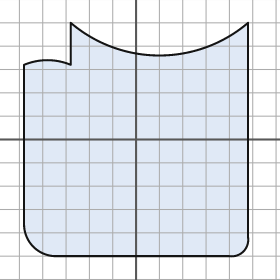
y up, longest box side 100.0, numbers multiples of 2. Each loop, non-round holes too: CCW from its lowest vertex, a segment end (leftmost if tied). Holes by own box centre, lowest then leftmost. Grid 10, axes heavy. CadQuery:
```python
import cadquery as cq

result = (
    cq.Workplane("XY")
    .moveTo(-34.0, -50.0)
    .lineTo(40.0, -50.0)
    .threePointArc((46.0, -48.0), (48.0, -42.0))
    .lineTo(48.0, 50.0)
    .threePointArc((10.0, 36.0), (-28.0, 50.0))
    .lineTo(-28.0, 32.0)
    .threePointArc((-38.0, 34.0), (-48.0, 32.0))
    .lineTo(-48.0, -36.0)
    .threePointArc((-44.0, -46.0), (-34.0, -50.0))
    .close()
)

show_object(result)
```